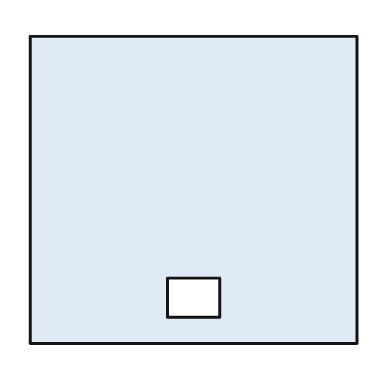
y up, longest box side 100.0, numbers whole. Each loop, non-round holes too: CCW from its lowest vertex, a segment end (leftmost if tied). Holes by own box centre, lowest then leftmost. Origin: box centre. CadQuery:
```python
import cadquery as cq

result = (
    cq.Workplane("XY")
    .moveTo(-50.0, -47.0)
    .lineTo(50.0, -47.0)
    .lineTo(50.0, 47.0)
    .lineTo(-50.0, 47.0)
    .close()
    .moveTo(-8.0, -39.0)
    .lineTo(8.0, -39.0)
    .lineTo(8.0, -27.0)
    .lineTo(-8.0, -27.0)
    .close()
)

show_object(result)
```